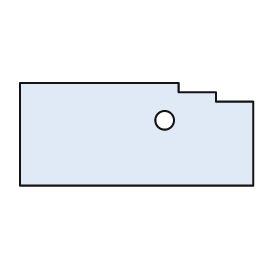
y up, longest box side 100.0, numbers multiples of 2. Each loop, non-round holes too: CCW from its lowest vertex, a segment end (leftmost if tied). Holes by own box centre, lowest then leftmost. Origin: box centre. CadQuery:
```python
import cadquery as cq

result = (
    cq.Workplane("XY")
    .moveTo(-50.0, -22.0)
    .lineTo(50.0, -22.0)
    .lineTo(50.0, 14.0)
    .lineTo(34.0, 14.0)
    .lineTo(34.0, 18.0)
    .lineTo(18.0, 18.0)
    .lineTo(18.0, 22.0)
    .lineTo(-50.0, 22.0)
    .close()
    .moveTo(12.0, 6.0)
    .circle(4.0)
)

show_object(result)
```